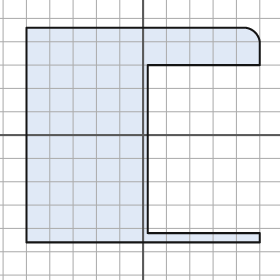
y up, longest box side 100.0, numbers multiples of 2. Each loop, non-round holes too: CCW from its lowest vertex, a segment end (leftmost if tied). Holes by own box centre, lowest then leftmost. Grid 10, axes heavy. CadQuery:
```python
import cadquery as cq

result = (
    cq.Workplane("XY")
    .moveTo(-50.0, -46.0)
    .lineTo(50.0, -46.0)
    .lineTo(50.0, -42.0)
    .lineTo(2.0, -42.0)
    .lineTo(2.0, 30.0)
    .lineTo(50.0, 30.0)
    .lineTo(50.0, 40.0)
    .threePointArc((48.0, 44.0), (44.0, 46.0))
    .lineTo(-50.0, 46.0)
    .close()
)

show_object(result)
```